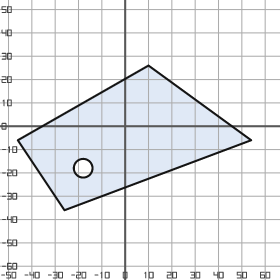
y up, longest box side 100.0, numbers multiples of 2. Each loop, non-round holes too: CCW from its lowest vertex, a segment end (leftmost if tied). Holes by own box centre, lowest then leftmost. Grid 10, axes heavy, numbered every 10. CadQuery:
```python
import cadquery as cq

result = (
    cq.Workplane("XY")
    .moveTo(-26.0, -36.0)
    .lineTo(54.0, -6.0)
    .lineTo(10.0, 26.0)
    .lineTo(-46.0, -6.0)
    .close()
    .moveTo(-18.0, -18.0)
    .circle(4.0)
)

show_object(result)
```